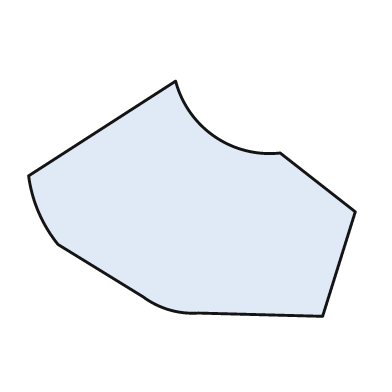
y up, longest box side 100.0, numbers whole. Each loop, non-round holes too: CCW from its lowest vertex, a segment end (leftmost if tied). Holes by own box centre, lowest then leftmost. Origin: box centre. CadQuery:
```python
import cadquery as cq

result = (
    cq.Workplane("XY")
    .moveTo(40.0, -36.0)
    .lineTo(50.0, -4.0)
    .lineTo(27.0, 14.0)
    .threePointArc((7.0, 19.0), (-5.0, 36.0))
    .lineTo(-50.0, 7.0)
    .threePointArc((-47.0, -4.0), (-41.0, -14.0))
    .lineTo(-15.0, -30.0)
    .threePointArc((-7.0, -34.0), (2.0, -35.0))
    .close()
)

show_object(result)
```